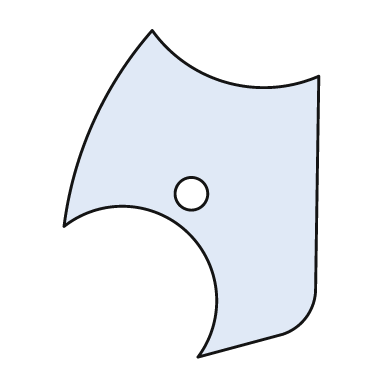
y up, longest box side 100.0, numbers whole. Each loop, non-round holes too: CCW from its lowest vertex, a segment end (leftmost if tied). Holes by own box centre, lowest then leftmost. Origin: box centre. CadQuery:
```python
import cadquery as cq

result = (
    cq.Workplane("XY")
    .moveTo(2.0, -50.0)
    .lineTo(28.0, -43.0)
    .threePointArc((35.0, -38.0), (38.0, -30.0))
    .lineTo(39.0, 36.0)
    .threePointArc((11.0, 34.0), (-12.0, 50.0))
    .threePointArc((-30.0, 22.0), (-39.0, -10.0))
    .threePointArc((-1.0, -12.0), (2.0, -50.0))
    .close()
    .moveTo(0.0, 0.0)
    .circle(5.0)
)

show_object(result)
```